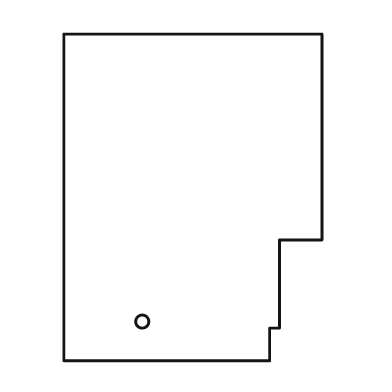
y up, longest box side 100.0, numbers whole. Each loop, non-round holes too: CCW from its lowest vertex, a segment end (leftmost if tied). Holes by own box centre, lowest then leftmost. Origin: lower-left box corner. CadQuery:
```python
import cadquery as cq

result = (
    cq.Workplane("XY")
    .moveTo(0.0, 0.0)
    .lineTo(63.0, 0.0)
    .lineTo(63.0, 10.0)
    .lineTo(66.0, 10.0)
    .lineTo(66.0, 37.0)
    .lineTo(79.0, 37.0)
    .lineTo(79.0, 100.0)
    .lineTo(0.0, 100.0)
    .close()
    .moveTo(24.0, 12.0)
    .circle(2.0)
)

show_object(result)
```